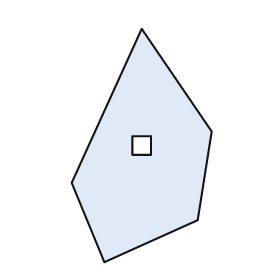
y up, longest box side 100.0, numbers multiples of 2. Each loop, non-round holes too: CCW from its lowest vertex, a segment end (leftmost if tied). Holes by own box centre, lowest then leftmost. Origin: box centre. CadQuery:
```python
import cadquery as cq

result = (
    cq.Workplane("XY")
    .moveTo(-16.0, -50.0)
    .lineTo(24.0, -32.0)
    .lineTo(30.0, 6.0)
    .lineTo(0.0, 50.0)
    .lineTo(-30.0, -16.0)
    .close()
    .moveTo(-4.0, -4.0)
    .lineTo(4.0, -4.0)
    .lineTo(4.0, 4.0)
    .lineTo(-4.0, 4.0)
    .close()
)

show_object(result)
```